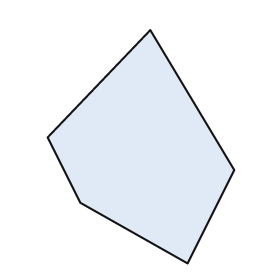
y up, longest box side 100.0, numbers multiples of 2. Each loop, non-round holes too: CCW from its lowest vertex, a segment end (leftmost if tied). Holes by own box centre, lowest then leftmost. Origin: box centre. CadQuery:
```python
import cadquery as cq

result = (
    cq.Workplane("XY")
    .moveTo(20.0, -50.0)
    .lineTo(40.0, -10.0)
    .lineTo(4.0, 50.0)
    .lineTo(-40.0, 4.0)
    .lineTo(-26.0, -24.0)
    .close()
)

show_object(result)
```